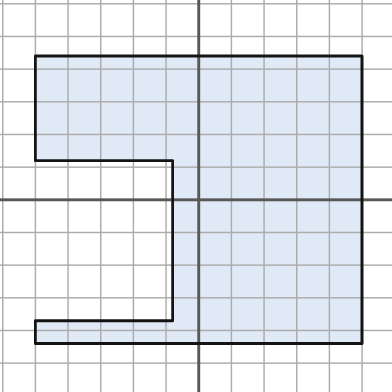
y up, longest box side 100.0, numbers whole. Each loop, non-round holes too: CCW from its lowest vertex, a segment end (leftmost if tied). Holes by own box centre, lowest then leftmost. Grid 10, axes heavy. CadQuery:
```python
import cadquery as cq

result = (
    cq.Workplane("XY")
    .moveTo(-50.0, -44.0)
    .lineTo(50.0, -44.0)
    .lineTo(50.0, 44.0)
    .lineTo(-50.0, 44.0)
    .lineTo(-50.0, 12.0)
    .lineTo(-8.0, 12.0)
    .lineTo(-8.0, -37.0)
    .lineTo(-50.0, -37.0)
    .close()
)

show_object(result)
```